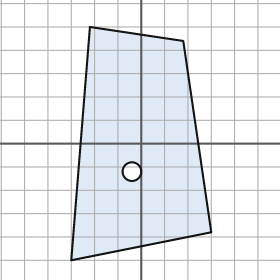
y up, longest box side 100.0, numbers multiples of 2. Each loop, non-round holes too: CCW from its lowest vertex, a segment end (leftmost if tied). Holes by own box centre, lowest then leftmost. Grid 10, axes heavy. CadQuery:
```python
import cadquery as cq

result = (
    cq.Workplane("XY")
    .moveTo(-30.0, -50.0)
    .lineTo(30.0, -38.0)
    .lineTo(18.0, 44.0)
    .lineTo(-22.0, 50.0)
    .close()
    .moveTo(-4.0, -12.0)
    .circle(4.0)
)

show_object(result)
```